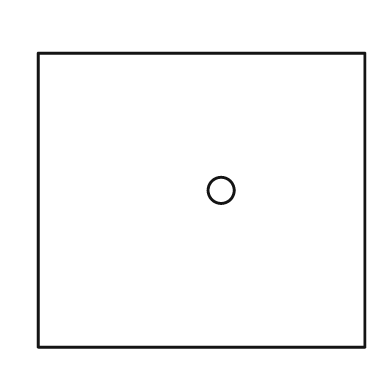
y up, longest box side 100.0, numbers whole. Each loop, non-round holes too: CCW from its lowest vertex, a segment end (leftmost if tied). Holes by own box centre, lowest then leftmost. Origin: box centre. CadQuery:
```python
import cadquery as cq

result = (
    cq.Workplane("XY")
    .moveTo(-50.0, -45.0)
    .lineTo(50.0, -45.0)
    .lineTo(50.0, 45.0)
    .lineTo(-50.0, 45.0)
    .close()
    .moveTo(6.0, 3.0)
    .circle(4.0)
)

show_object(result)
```